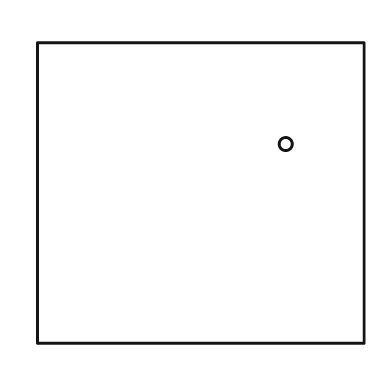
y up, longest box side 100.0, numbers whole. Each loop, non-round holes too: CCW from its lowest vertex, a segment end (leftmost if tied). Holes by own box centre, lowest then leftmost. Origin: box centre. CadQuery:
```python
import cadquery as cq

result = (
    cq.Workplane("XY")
    .moveTo(-50.0, -46.0)
    .lineTo(50.0, -46.0)
    .lineTo(50.0, 46.0)
    .lineTo(-50.0, 46.0)
    .close()
    .moveTo(26.0, 15.0)
    .circle(2.0)
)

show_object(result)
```